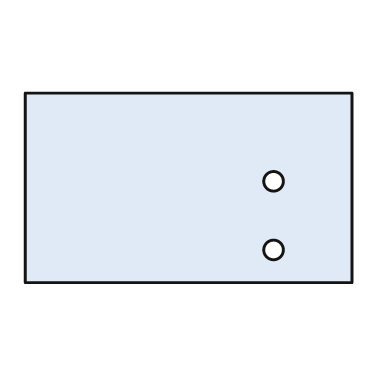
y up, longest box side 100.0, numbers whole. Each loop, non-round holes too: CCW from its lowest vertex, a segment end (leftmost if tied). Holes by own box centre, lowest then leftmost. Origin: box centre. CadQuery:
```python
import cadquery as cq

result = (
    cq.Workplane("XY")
    .moveTo(-50.0, -29.0)
    .lineTo(50.0, -29.0)
    .lineTo(50.0, 29.0)
    .lineTo(-50.0, 29.0)
    .close()
    .moveTo(26.0, -19.0)
    .circle(3.0)
    .moveTo(26.0, 2.0)
    .circle(3.0)
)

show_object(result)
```